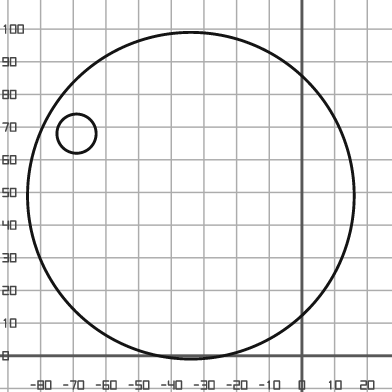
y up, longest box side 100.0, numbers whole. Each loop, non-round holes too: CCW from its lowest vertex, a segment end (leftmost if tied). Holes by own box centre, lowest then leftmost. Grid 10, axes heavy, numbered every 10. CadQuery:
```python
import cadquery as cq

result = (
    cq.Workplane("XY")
    .moveTo(-34.0, 49.0)
    .circle(50.0)
    .moveTo(-69.0, 68.0)
    .circle(6.0)
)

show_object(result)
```